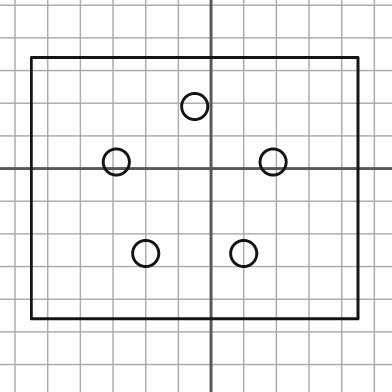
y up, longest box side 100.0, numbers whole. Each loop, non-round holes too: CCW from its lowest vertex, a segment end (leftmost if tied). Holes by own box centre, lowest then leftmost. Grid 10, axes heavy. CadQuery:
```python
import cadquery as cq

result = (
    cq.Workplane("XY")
    .moveTo(-55.0, -46.0)
    .lineTo(45.0, -46.0)
    .lineTo(45.0, 34.0)
    .lineTo(-55.0, 34.0)
    .close()
    .moveTo(-20.0, -26.0)
    .circle(4.0)
    .moveTo(10.0, -26.0)
    .circle(4.0)
    .moveTo(-29.0, 2.0)
    .circle(4.0)
    .moveTo(19.0, 2.0)
    .circle(4.0)
    .moveTo(-5.0, 19.0)
    .circle(4.0)
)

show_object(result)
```